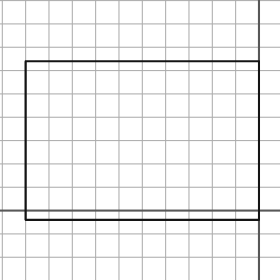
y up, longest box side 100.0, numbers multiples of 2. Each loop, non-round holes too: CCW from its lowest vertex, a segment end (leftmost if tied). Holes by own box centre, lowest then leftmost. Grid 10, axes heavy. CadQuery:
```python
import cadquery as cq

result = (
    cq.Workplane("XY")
    .moveTo(-100.0, -4.0)
    .lineTo(0.0, -4.0)
    .lineTo(0.0, 64.0)
    .lineTo(-100.0, 64.0)
    .close()
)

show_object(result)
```